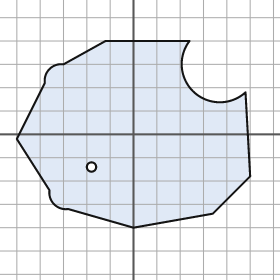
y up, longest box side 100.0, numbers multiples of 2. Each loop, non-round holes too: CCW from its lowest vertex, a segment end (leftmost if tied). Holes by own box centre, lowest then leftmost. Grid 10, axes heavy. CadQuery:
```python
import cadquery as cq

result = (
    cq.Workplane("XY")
    .moveTo(0.0, -40.0)
    .lineTo(34.0, -34.0)
    .lineTo(50.0, -18.0)
    .lineTo(48.0, 18.0)
    .threePointArc((26.0, 18.0), (24.0, 40.0))
    .lineTo(-12.0, 40.0)
    .lineTo(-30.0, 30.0)
    .threePointArc((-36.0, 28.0), (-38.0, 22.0))
    .lineTo(-50.0, -2.0)
    .lineTo(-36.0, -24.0)
    .threePointArc((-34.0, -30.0), (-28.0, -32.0))
    .close()
    .moveTo(-18.0, -14.0)
    .circle(2.0)
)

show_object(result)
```